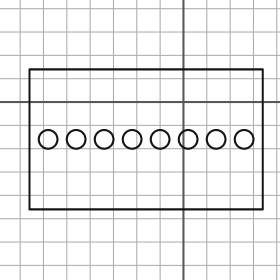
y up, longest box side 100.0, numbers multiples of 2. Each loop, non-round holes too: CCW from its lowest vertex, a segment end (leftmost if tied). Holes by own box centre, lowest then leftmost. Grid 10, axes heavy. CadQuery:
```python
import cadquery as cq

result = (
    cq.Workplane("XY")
    .moveTo(-66.0, -46.0)
    .lineTo(34.0, -46.0)
    .lineTo(34.0, 14.0)
    .lineTo(-66.0, 14.0)
    .close()
    .moveTo(-58.0, -16.0)
    .circle(4.0)
    .moveTo(-46.0, -16.0)
    .circle(4.0)
    .moveTo(-34.0, -16.0)
    .circle(4.0)
    .moveTo(-22.0, -16.0)
    .circle(4.0)
    .moveTo(-10.0, -16.0)
    .circle(4.0)
    .moveTo(2.0, -16.0)
    .circle(4.0)
    .moveTo(14.0, -16.0)
    .circle(4.0)
    .moveTo(26.0, -16.0)
    .circle(4.0)
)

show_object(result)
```